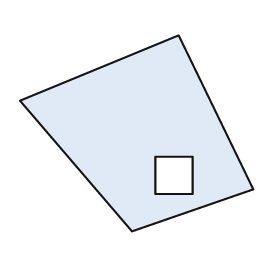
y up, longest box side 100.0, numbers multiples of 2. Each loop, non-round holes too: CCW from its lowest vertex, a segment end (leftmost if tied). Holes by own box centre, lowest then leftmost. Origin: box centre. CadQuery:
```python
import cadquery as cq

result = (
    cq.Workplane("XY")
    .moveTo(-2.0, -42.0)
    .lineTo(50.0, -24.0)
    .lineTo(18.0, 42.0)
    .lineTo(-50.0, 14.0)
    .close()
    .moveTo(8.0, -26.0)
    .lineTo(24.0, -26.0)
    .lineTo(24.0, -10.0)
    .lineTo(8.0, -10.0)
    .close()
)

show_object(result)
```